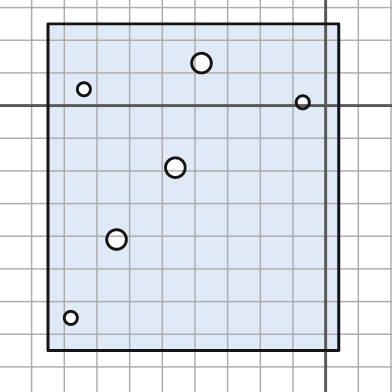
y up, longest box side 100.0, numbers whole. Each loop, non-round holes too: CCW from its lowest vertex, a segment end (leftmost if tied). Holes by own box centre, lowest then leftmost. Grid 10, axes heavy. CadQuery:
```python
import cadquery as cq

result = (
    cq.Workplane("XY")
    .moveTo(-85.0, -75.0)
    .lineTo(4.0, -75.0)
    .lineTo(4.0, 25.0)
    .lineTo(-85.0, 25.0)
    .close()
    .moveTo(-78.0, -65.0)
    .circle(2.0)
    .moveTo(-64.0, -41.0)
    .circle(3.0)
    .moveTo(-46.0, -19.0)
    .circle(3.0)
    .moveTo(-7.0, 1.0)
    .circle(2.0)
    .moveTo(-74.0, 5.0)
    .circle(2.0)
    .moveTo(-38.0, 13.0)
    .circle(3.0)
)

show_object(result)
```